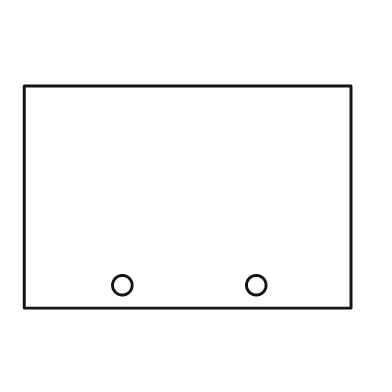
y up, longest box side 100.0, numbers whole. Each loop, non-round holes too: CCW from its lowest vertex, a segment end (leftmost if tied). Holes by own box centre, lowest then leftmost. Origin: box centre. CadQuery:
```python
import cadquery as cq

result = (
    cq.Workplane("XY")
    .moveTo(-50.0, -34.0)
    .lineTo(50.0, -34.0)
    .lineTo(50.0, 34.0)
    .lineTo(-50.0, 34.0)
    .close()
    .moveTo(-20.0, -27.0)
    .circle(3.0)
    .moveTo(21.0, -27.0)
    .circle(3.0)
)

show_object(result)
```